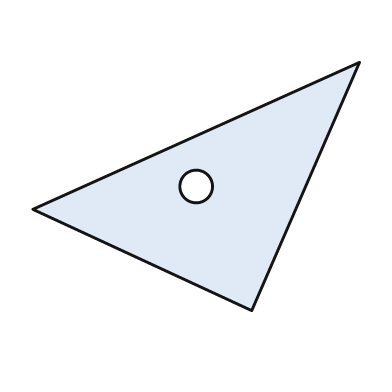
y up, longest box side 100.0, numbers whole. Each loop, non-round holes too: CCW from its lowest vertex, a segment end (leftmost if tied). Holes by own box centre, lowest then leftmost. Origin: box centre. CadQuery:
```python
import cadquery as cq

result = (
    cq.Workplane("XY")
    .moveTo(17.0, -38.0)
    .lineTo(50.0, 38.0)
    .lineTo(-50.0, -7.0)
    .close()
    .moveTo(0.0, 0.0)
    .circle(5.0)
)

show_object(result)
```